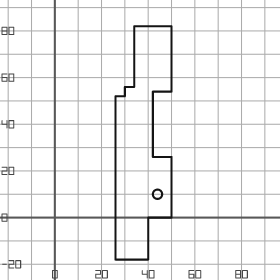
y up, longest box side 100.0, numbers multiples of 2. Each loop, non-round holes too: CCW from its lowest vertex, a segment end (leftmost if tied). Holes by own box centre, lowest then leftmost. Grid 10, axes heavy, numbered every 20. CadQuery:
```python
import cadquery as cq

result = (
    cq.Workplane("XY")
    .moveTo(26.0, -18.0)
    .lineTo(40.0, -18.0)
    .lineTo(40.0, 0.0)
    .lineTo(50.0, 0.0)
    .lineTo(50.0, 26.0)
    .lineTo(42.0, 26.0)
    .lineTo(42.0, 54.0)
    .lineTo(50.0, 54.0)
    .lineTo(50.0, 82.0)
    .lineTo(34.0, 82.0)
    .lineTo(34.0, 56.0)
    .lineTo(30.0, 56.0)
    .lineTo(30.0, 52.0)
    .lineTo(26.0, 52.0)
    .close()
    .moveTo(44.0, 10.0)
    .circle(2.0)
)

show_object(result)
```